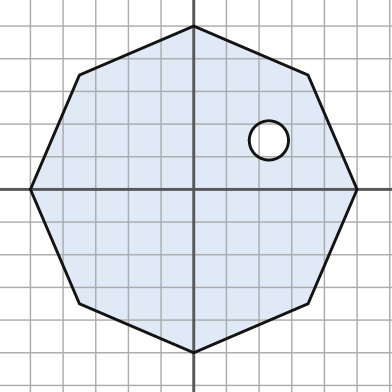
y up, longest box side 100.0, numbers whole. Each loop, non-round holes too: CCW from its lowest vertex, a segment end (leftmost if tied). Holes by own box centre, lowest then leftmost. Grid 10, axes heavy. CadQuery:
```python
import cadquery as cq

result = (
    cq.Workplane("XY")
    .moveTo(0.0, -50.0)
    .lineTo(35.0, -35.0)
    .lineTo(50.0, 0.0)
    .lineTo(35.0, 35.0)
    .lineTo(0.0, 50.0)
    .lineTo(-35.0, 35.0)
    .lineTo(-50.0, 0.0)
    .lineTo(-35.0, -35.0)
    .close()
    .moveTo(23.0, 15.0)
    .circle(6.0)
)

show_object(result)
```